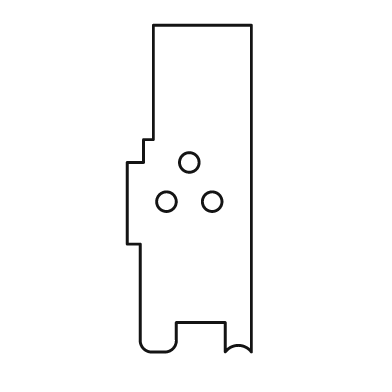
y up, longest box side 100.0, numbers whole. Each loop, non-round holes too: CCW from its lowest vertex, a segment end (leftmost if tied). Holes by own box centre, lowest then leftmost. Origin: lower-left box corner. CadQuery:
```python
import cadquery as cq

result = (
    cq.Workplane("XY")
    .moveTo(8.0, 0.0)
    .lineTo(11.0, 0.0)
    .threePointArc((14.0, 1.0), (15.0, 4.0))
    .lineTo(15.0, 9.0)
    .lineTo(30.0, 9.0)
    .lineTo(30.0, 0.0)
    .threePointArc((34.0, 2.0), (38.0, 0.0))
    .lineTo(38.0, 100.0)
    .lineTo(8.0, 100.0)
    .lineTo(8.0, 65.0)
    .lineTo(5.0, 65.0)
    .lineTo(5.0, 58.0)
    .lineTo(0.0, 58.0)
    .lineTo(0.0, 33.0)
    .lineTo(4.0, 33.0)
    .lineTo(4.0, 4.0)
    .threePointArc((5.0, 1.0), (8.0, 0.0))
    .close()
    .moveTo(12.0, 46.0)
    .circle(3.0)
    .moveTo(26.0, 46.0)
    .circle(3.0)
    .moveTo(19.0, 58.0)
    .circle(3.0)
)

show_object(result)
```